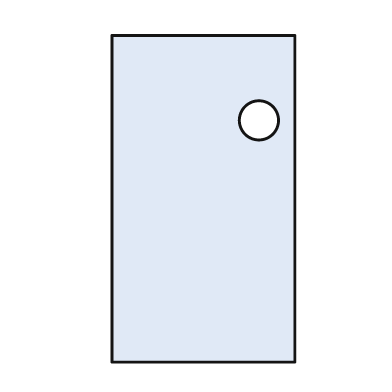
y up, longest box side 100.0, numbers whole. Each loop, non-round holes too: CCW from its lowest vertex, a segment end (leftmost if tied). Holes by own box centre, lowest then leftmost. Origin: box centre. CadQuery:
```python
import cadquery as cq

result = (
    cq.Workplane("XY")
    .moveTo(-28.0, -50.0)
    .lineTo(28.0, -50.0)
    .lineTo(28.0, 50.0)
    .lineTo(-28.0, 50.0)
    .close()
    .moveTo(17.0, 24.0)
    .circle(6.0)
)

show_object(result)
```